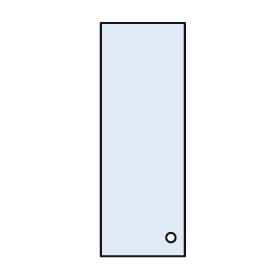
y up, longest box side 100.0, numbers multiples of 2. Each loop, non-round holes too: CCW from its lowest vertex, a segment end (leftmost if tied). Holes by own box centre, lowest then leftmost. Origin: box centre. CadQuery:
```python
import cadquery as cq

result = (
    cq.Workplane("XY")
    .moveTo(-18.0, -50.0)
    .lineTo(18.0, -50.0)
    .lineTo(18.0, 50.0)
    .lineTo(-18.0, 50.0)
    .close()
    .moveTo(12.0, -42.0)
    .circle(2.0)
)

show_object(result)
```